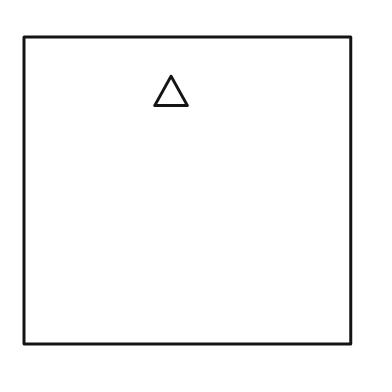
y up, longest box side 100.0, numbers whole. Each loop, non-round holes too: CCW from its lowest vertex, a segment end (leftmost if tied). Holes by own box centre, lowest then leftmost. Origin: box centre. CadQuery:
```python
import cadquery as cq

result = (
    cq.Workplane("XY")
    .moveTo(-50.0, -47.0)
    .lineTo(50.0, -47.0)
    .lineTo(50.0, 47.0)
    .lineTo(-50.0, 47.0)
    .close()
    .moveTo(-10.0, 26.0)
    .lineTo(0.0, 26.0)
    .lineTo(-5.0, 35.0)
    .close()
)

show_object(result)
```